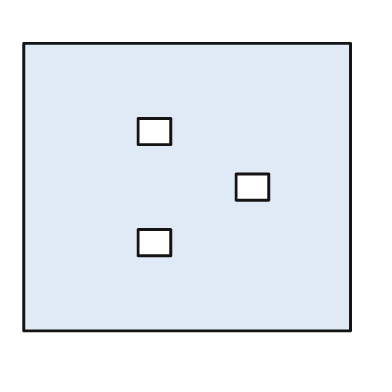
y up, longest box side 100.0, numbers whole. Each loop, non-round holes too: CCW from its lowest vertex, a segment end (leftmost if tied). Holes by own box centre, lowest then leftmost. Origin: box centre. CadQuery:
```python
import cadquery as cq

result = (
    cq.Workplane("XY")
    .moveTo(-50.0, -44.0)
    .lineTo(50.0, -44.0)
    .lineTo(50.0, 44.0)
    .lineTo(-50.0, 44.0)
    .close()
    .moveTo(-15.0, -21.0)
    .lineTo(-5.0, -21.0)
    .lineTo(-5.0, -13.0)
    .lineTo(-15.0, -13.0)
    .close()
    .moveTo(15.0, -4.0)
    .lineTo(25.0, -4.0)
    .lineTo(25.0, 4.0)
    .lineTo(15.0, 4.0)
    .close()
    .moveTo(-15.0, 13.0)
    .lineTo(-5.0, 13.0)
    .lineTo(-5.0, 21.0)
    .lineTo(-15.0, 21.0)
    .close()
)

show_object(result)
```